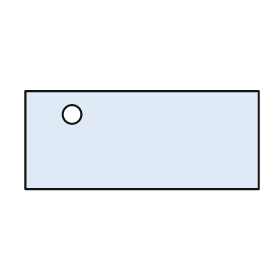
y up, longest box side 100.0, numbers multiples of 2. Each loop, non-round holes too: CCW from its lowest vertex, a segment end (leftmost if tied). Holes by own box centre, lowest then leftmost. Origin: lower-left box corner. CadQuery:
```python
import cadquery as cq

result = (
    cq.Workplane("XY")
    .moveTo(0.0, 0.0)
    .lineTo(100.0, 0.0)
    .lineTo(100.0, 42.0)
    .lineTo(0.0, 42.0)
    .close()
    .moveTo(20.0, 32.0)
    .circle(4.0)
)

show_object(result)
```